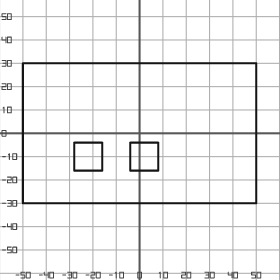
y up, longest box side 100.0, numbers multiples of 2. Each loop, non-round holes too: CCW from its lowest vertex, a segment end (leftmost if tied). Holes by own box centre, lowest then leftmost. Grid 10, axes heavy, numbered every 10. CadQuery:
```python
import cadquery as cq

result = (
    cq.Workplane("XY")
    .moveTo(-50.0, -30.0)
    .lineTo(50.0, -30.0)
    .lineTo(50.0, 30.0)
    .lineTo(-50.0, 30.0)
    .close()
    .moveTo(-28.0, -16.0)
    .lineTo(-16.0, -16.0)
    .lineTo(-16.0, -4.0)
    .lineTo(-28.0, -4.0)
    .close()
    .moveTo(-4.0, -16.0)
    .lineTo(8.0, -16.0)
    .lineTo(8.0, -4.0)
    .lineTo(-4.0, -4.0)
    .close()
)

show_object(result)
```